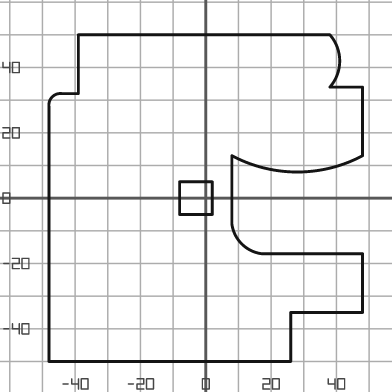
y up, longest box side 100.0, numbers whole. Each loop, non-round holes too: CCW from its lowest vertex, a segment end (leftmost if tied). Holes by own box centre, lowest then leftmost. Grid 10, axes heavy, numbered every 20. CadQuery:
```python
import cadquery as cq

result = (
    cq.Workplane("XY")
    .moveTo(-48.0, -50.0)
    .lineTo(26.0, -50.0)
    .lineTo(26.0, -35.0)
    .lineTo(48.0, -35.0)
    .lineTo(48.0, -17.0)
    .lineTo(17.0, -17.0)
    .threePointArc((11.0, -14.0), (8.0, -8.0))
    .lineTo(8.0, 13.0)
    .threePointArc((28.0, 8.0), (48.0, 13.0))
    .lineTo(48.0, 34.0)
    .lineTo(38.0, 34.0)
    .threePointArc((41.0, 42.0), (38.0, 50.0))
    .lineTo(-39.0, 50.0)
    .lineTo(-39.0, 32.0)
    .lineTo(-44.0, 32.0)
    .threePointArc((-47.0, 31.0), (-48.0, 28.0))
    .close()
    .moveTo(-8.0, -5.0)
    .lineTo(2.0, -5.0)
    .lineTo(2.0, 5.0)
    .lineTo(-8.0, 5.0)
    .close()
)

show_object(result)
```